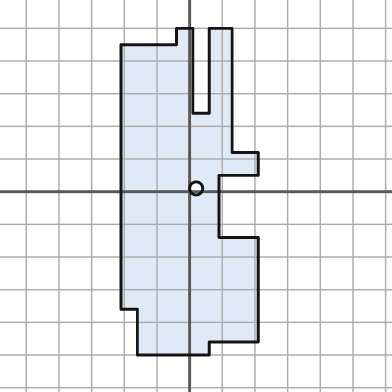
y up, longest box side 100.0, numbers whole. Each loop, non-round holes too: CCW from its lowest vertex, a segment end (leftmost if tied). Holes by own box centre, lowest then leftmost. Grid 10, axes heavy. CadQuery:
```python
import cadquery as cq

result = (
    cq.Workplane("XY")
    .moveTo(-16.0, -50.0)
    .lineTo(6.0, -50.0)
    .lineTo(6.0, -46.0)
    .lineTo(21.0, -46.0)
    .lineTo(21.0, -14.0)
    .lineTo(9.0, -14.0)
    .lineTo(9.0, 5.0)
    .lineTo(21.0, 5.0)
    .lineTo(21.0, 12.0)
    .lineTo(13.0, 12.0)
    .lineTo(13.0, 50.0)
    .lineTo(6.0, 50.0)
    .lineTo(6.0, 24.0)
    .lineTo(1.0, 24.0)
    .lineTo(1.0, 50.0)
    .lineTo(-4.0, 50.0)
    .lineTo(-4.0, 45.0)
    .lineTo(-21.0, 45.0)
    .lineTo(-21.0, -36.0)
    .lineTo(-16.0, -36.0)
    .close()
    .moveTo(2.0, 1.0)
    .circle(2.0)
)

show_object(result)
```